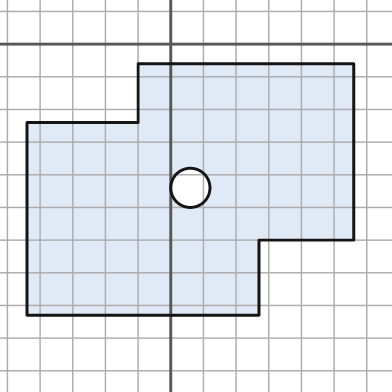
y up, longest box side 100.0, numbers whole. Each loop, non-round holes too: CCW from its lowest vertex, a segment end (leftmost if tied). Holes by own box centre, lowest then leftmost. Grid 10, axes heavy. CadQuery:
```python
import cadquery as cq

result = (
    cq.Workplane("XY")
    .moveTo(-44.0, -83.0)
    .lineTo(27.0, -83.0)
    .lineTo(27.0, -60.0)
    .lineTo(56.0, -60.0)
    .lineTo(56.0, -6.0)
    .lineTo(-10.0, -6.0)
    .lineTo(-10.0, -24.0)
    .lineTo(-44.0, -24.0)
    .close()
    .moveTo(6.0, -44.0)
    .circle(6.0)
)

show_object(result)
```